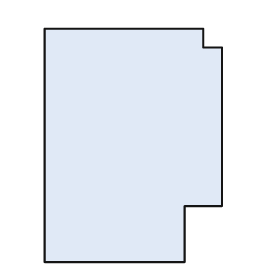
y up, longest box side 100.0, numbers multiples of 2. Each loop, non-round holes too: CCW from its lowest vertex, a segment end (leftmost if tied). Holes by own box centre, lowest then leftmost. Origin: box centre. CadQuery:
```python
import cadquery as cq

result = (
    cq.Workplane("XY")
    .moveTo(-38.0, -50.0)
    .lineTo(22.0, -50.0)
    .lineTo(22.0, -26.0)
    .lineTo(38.0, -26.0)
    .lineTo(38.0, 42.0)
    .lineTo(30.0, 42.0)
    .lineTo(30.0, 50.0)
    .lineTo(-38.0, 50.0)
    .close()
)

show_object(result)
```